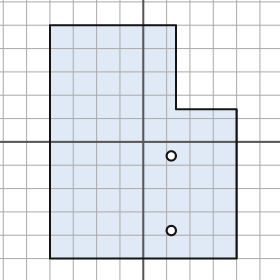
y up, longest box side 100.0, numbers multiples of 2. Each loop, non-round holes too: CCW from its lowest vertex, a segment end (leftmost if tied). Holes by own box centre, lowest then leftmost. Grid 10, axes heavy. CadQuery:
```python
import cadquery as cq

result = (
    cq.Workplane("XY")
    .moveTo(-40.0, -50.0)
    .lineTo(40.0, -50.0)
    .lineTo(40.0, 14.0)
    .lineTo(14.0, 14.0)
    .lineTo(14.0, 50.0)
    .lineTo(-40.0, 50.0)
    .close()
    .moveTo(12.0, -38.0)
    .circle(2.0)
    .moveTo(12.0, -6.0)
    .circle(2.0)
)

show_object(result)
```